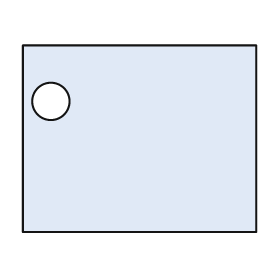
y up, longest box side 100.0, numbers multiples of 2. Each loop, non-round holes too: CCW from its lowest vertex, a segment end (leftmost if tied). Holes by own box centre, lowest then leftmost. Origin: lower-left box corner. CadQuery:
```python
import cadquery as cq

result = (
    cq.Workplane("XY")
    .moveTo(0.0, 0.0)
    .lineTo(100.0, 0.0)
    .lineTo(100.0, 80.0)
    .lineTo(0.0, 80.0)
    .close()
    .moveTo(12.0, 56.0)
    .circle(8.0)
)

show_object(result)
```